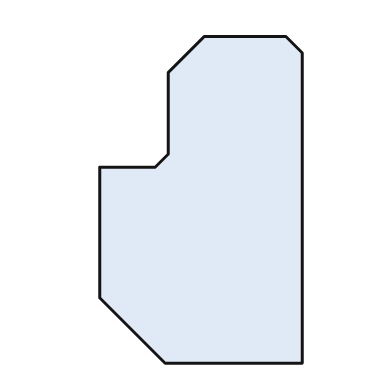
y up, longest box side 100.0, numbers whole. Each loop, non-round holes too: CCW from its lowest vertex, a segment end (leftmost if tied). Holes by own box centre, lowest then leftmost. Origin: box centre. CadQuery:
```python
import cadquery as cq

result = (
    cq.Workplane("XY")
    .moveTo(-11.0, -50.0)
    .lineTo(31.0, -50.0)
    .lineTo(31.0, 45.0)
    .lineTo(26.0, 50.0)
    .lineTo(1.0, 50.0)
    .lineTo(-10.0, 39.0)
    .lineTo(-10.0, 14.0)
    .lineTo(-14.0, 10.0)
    .lineTo(-31.0, 10.0)
    .lineTo(-31.0, -30.0)
    .close()
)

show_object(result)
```